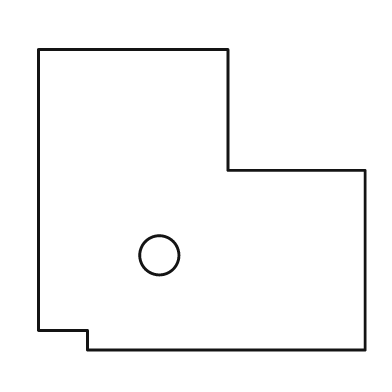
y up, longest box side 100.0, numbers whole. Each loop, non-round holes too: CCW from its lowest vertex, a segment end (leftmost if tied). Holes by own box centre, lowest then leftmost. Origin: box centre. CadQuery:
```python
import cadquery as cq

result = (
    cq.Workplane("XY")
    .moveTo(-35.0, -46.0)
    .lineTo(50.0, -46.0)
    .lineTo(50.0, 9.0)
    .lineTo(8.0, 9.0)
    .lineTo(8.0, 46.0)
    .lineTo(-50.0, 46.0)
    .lineTo(-50.0, -40.0)
    .lineTo(-35.0, -40.0)
    .close()
    .moveTo(-13.0, -17.0)
    .circle(6.0)
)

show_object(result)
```